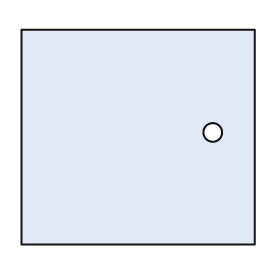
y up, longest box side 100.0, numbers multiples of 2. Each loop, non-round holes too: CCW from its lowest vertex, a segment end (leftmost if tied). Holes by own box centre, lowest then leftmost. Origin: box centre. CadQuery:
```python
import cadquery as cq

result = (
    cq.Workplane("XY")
    .moveTo(-50.0, -46.0)
    .lineTo(50.0, -46.0)
    .lineTo(50.0, 46.0)
    .lineTo(-50.0, 46.0)
    .close()
    .moveTo(32.0, 2.0)
    .circle(4.0)
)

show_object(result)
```